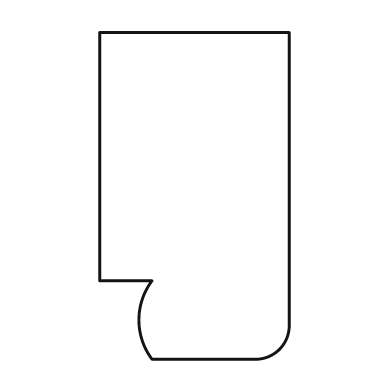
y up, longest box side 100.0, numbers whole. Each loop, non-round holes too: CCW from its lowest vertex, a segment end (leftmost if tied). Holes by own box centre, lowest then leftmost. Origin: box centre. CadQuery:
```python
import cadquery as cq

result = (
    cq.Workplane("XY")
    .moveTo(-13.0, -50.0)
    .lineTo(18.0, -50.0)
    .threePointArc((26.0, -47.0), (29.0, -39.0))
    .lineTo(29.0, 50.0)
    .lineTo(-29.0, 50.0)
    .lineTo(-29.0, -26.0)
    .lineTo(-13.0, -26.0)
    .threePointArc((-17.0, -38.0), (-13.0, -50.0))
    .close()
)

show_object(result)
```